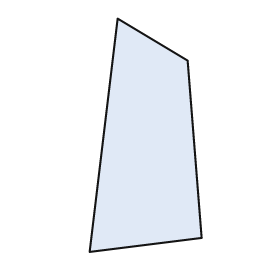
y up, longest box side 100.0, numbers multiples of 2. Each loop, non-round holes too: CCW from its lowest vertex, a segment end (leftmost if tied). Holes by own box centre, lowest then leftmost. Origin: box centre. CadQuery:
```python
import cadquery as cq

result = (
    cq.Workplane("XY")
    .moveTo(-24.0, -50.0)
    .lineTo(24.0, -44.0)
    .lineTo(18.0, 32.0)
    .lineTo(-12.0, 50.0)
    .close()
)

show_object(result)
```